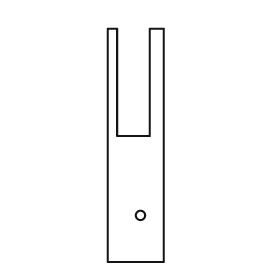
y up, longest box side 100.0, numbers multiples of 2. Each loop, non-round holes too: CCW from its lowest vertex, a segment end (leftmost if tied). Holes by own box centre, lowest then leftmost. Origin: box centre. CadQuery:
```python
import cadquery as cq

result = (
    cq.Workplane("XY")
    .moveTo(-12.0, -50.0)
    .lineTo(12.0, -50.0)
    .lineTo(12.0, 50.0)
    .lineTo(6.0, 50.0)
    .lineTo(6.0, 4.0)
    .lineTo(-8.0, 4.0)
    .lineTo(-8.0, 50.0)
    .lineTo(-12.0, 50.0)
    .close()
    .moveTo(2.0, -30.0)
    .circle(2.0)
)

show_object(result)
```